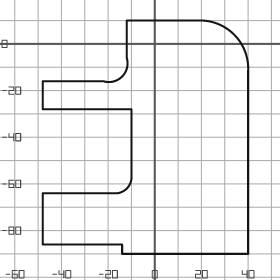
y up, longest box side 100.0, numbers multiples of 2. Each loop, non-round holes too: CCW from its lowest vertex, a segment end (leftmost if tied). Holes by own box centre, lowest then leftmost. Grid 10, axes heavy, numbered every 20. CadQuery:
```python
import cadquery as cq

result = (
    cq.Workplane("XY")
    .moveTo(-14.0, -90.0)
    .lineTo(40.0, -90.0)
    .lineTo(40.0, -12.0)
    .threePointArc((34.0, 4.0), (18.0, 10.0))
    .lineTo(-12.0, 10.0)
    .lineTo(-12.0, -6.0)
    .threePointArc((-14.0, -14.0), (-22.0, -16.0))
    .lineTo(-48.0, -16.0)
    .lineTo(-48.0, -28.0)
    .lineTo(-10.0, -28.0)
    .lineTo(-10.0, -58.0)
    .threePointArc((-12.0, -62.0), (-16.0, -64.0))
    .lineTo(-48.0, -64.0)
    .lineTo(-48.0, -86.0)
    .lineTo(-14.0, -86.0)
    .close()
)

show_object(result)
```